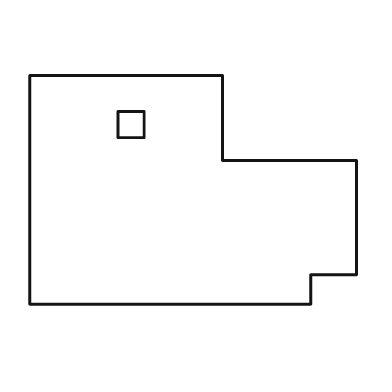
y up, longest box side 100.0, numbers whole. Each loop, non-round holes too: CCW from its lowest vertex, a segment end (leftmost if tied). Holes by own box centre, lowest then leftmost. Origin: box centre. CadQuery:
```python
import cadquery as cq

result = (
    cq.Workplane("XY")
    .moveTo(-50.0, -35.0)
    .lineTo(36.0, -35.0)
    .lineTo(36.0, -26.0)
    .lineTo(50.0, -26.0)
    .lineTo(50.0, 9.0)
    .lineTo(9.0, 9.0)
    .lineTo(9.0, 35.0)
    .lineTo(-50.0, 35.0)
    .close()
    .moveTo(-23.0, 16.0)
    .lineTo(-15.0, 16.0)
    .lineTo(-15.0, 24.0)
    .lineTo(-23.0, 24.0)
    .close()
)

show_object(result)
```